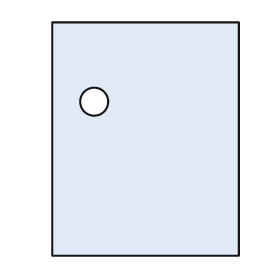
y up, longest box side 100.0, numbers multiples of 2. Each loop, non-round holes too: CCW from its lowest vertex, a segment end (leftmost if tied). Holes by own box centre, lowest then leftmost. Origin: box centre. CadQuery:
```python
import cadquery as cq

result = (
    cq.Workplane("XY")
    .moveTo(-40.0, -50.0)
    .lineTo(40.0, -50.0)
    .lineTo(40.0, 50.0)
    .lineTo(-40.0, 50.0)
    .close()
    .moveTo(-22.0, 16.0)
    .circle(6.0)
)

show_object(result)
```